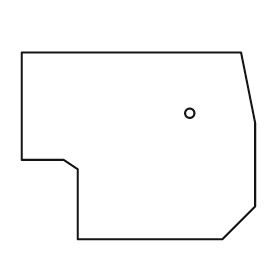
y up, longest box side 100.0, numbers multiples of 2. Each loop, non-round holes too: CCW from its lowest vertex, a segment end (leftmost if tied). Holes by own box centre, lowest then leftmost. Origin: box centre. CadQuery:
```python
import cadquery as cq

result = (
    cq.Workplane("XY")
    .moveTo(-26.0, -40.0)
    .lineTo(36.0, -40.0)
    .lineTo(50.0, -26.0)
    .lineTo(50.0, 10.0)
    .lineTo(44.0, 40.0)
    .lineTo(-50.0, 40.0)
    .lineTo(-50.0, -6.0)
    .lineTo(-32.0, -6.0)
    .lineTo(-26.0, -10.0)
    .close()
    .moveTo(22.0, 14.0)
    .circle(2.0)
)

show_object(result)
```